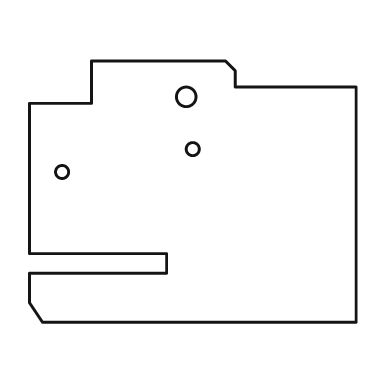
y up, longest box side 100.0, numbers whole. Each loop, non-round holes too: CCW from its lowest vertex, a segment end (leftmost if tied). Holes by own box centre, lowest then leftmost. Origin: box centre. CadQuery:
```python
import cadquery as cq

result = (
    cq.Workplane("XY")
    .moveTo(-46.0, -40.0)
    .lineTo(50.0, -40.0)
    .lineTo(50.0, 32.0)
    .lineTo(13.0, 32.0)
    .lineTo(13.0, 37.0)
    .lineTo(10.0, 40.0)
    .lineTo(-31.0, 40.0)
    .lineTo(-31.0, 27.0)
    .lineTo(-50.0, 27.0)
    .lineTo(-50.0, -19.0)
    .lineTo(-8.0, -19.0)
    .lineTo(-8.0, -25.0)
    .lineTo(-50.0, -25.0)
    .lineTo(-50.0, -34.0)
    .close()
    .moveTo(-40.0, 6.0)
    .circle(2.0)
    .moveTo(0.0, 13.0)
    .circle(2.0)
    .moveTo(-2.0, 29.0)
    .circle(3.0)
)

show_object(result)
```